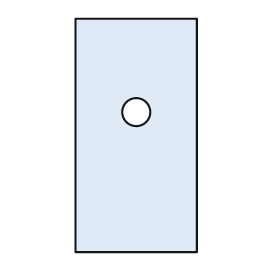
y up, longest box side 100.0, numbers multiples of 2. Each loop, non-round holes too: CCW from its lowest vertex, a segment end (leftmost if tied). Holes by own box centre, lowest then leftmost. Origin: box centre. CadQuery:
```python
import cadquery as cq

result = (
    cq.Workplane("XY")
    .moveTo(-26.0, -50.0)
    .lineTo(26.0, -50.0)
    .lineTo(26.0, 50.0)
    .lineTo(-26.0, 50.0)
    .close()
    .moveTo(0.0, 10.0)
    .circle(6.0)
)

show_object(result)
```